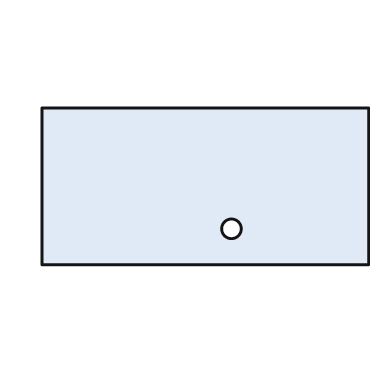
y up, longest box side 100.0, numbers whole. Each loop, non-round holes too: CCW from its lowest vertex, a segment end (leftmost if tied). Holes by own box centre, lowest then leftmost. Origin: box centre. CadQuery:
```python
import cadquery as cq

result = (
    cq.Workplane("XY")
    .moveTo(-50.0, -24.0)
    .lineTo(50.0, -24.0)
    .lineTo(50.0, 24.0)
    .lineTo(-50.0, 24.0)
    .close()
    .moveTo(8.0, -13.0)
    .circle(3.0)
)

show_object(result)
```